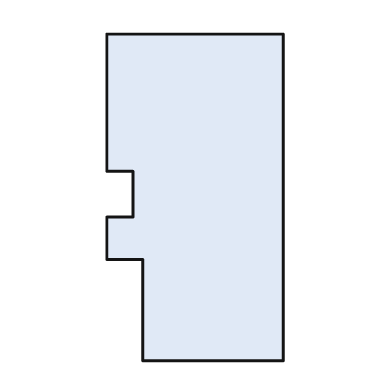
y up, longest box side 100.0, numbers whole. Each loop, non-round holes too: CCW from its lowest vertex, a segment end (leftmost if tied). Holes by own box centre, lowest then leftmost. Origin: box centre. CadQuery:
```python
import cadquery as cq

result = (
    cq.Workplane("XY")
    .moveTo(-16.0, -50.0)
    .lineTo(27.0, -50.0)
    .lineTo(27.0, 50.0)
    .lineTo(-27.0, 50.0)
    .lineTo(-27.0, 8.0)
    .lineTo(-19.0, 8.0)
    .lineTo(-19.0, -6.0)
    .lineTo(-27.0, -6.0)
    .lineTo(-27.0, -19.0)
    .lineTo(-16.0, -19.0)
    .close()
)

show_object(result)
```